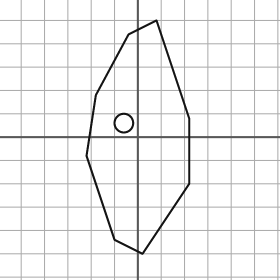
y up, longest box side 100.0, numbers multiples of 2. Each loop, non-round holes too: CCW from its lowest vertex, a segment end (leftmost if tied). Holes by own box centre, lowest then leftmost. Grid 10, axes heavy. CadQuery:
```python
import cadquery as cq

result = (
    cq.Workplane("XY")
    .moveTo(2.0, -50.0)
    .lineTo(22.0, -20.0)
    .lineTo(22.0, 8.0)
    .lineTo(8.0, 50.0)
    .lineTo(-4.0, 44.0)
    .lineTo(-18.0, 18.0)
    .lineTo(-22.0, -8.0)
    .lineTo(-10.0, -44.0)
    .close()
    .moveTo(-6.0, 6.0)
    .circle(4.0)
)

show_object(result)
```